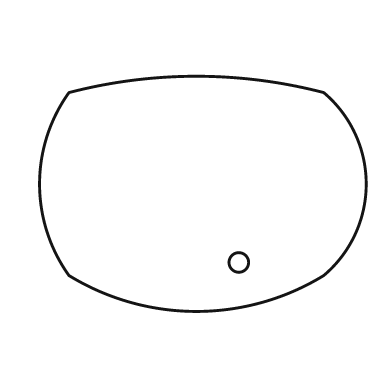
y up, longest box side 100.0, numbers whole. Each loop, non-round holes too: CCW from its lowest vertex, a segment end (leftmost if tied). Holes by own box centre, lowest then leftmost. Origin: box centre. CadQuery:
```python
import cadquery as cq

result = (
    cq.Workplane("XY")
    .moveTo(-41.0, -25.0)
    .threePointArc((-2.0, -36.0), (37.0, -25.0))
    .threePointArc((50.0, 3.0), (37.0, 31.0))
    .threePointArc((-2.0, 36.0), (-41.0, 31.0))
    .threePointArc((-50.0, 3.0), (-41.0, -25.0))
    .close()
    .moveTo(11.0, -21.0)
    .circle(3.0)
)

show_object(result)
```